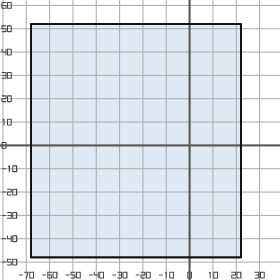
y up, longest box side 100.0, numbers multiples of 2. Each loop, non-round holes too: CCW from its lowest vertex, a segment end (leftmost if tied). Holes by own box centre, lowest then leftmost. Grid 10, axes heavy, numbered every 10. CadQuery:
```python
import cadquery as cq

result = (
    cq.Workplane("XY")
    .moveTo(-68.0, -48.0)
    .lineTo(22.0, -48.0)
    .lineTo(22.0, 52.0)
    .lineTo(-68.0, 52.0)
    .close()
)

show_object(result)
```